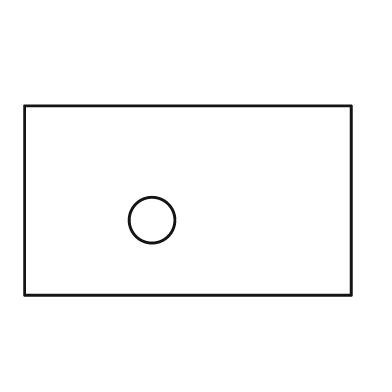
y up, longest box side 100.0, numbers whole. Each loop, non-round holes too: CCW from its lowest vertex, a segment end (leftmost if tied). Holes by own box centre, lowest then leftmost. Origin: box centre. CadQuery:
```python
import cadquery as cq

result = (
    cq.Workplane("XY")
    .moveTo(-50.0, -29.0)
    .lineTo(50.0, -29.0)
    .lineTo(50.0, 29.0)
    .lineTo(-50.0, 29.0)
    .close()
    .moveTo(-11.0, -6.0)
    .circle(7.0)
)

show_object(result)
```